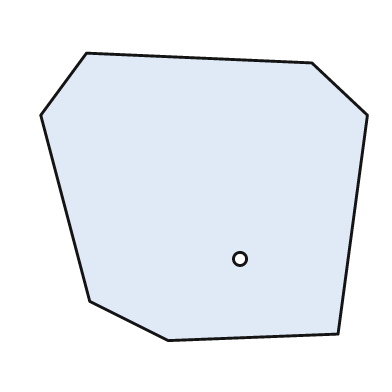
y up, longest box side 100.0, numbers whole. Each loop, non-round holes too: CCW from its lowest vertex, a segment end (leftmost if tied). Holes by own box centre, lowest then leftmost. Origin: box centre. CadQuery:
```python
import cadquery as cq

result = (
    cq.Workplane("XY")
    .moveTo(-11.0, -44.0)
    .lineTo(41.0, -42.0)
    .lineTo(50.0, 25.0)
    .lineTo(33.0, 41.0)
    .lineTo(-36.0, 44.0)
    .lineTo(-50.0, 25.0)
    .lineTo(-35.0, -32.0)
    .close()
    .moveTo(11.0, -19.0)
    .circle(2.0)
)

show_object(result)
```